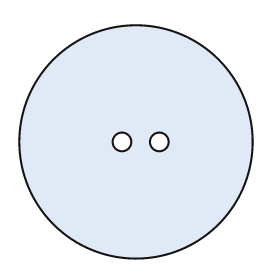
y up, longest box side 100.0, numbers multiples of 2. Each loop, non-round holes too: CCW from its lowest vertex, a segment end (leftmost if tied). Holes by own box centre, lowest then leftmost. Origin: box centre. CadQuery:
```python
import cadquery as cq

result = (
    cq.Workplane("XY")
    .moveTo(0.0, 0.0)
    .circle(50.0)
    .moveTo(-6.0, 0.0)
    .circle(4.0)
    .moveTo(10.0, 0.0)
    .circle(4.0)
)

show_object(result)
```